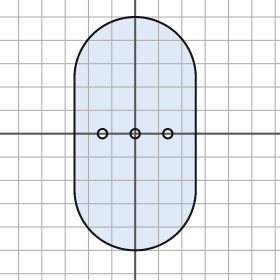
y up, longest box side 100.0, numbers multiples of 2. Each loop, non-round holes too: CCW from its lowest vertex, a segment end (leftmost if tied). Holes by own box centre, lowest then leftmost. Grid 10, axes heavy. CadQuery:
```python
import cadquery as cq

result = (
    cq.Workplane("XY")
    .moveTo(-26.0, -24.0)
    .threePointArc((0.0, -50.0), (26.0, -24.0))
    .lineTo(26.0, 24.0)
    .threePointArc((0.0, 50.0), (-26.0, 24.0))
    .close()
    .moveTo(-14.0, 0.0)
    .circle(2.0)
    .moveTo(0.0, 0.0)
    .circle(2.0)
    .moveTo(14.0, 0.0)
    .circle(2.0)
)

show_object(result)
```